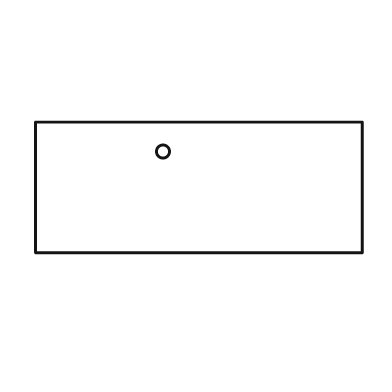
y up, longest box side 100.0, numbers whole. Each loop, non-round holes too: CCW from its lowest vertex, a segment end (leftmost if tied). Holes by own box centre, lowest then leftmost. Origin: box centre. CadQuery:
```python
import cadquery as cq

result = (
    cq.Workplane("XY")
    .moveTo(-50.0, -20.0)
    .lineTo(50.0, -20.0)
    .lineTo(50.0, 20.0)
    .lineTo(-50.0, 20.0)
    .close()
    .moveTo(-11.0, 11.0)
    .circle(2.0)
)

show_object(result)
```